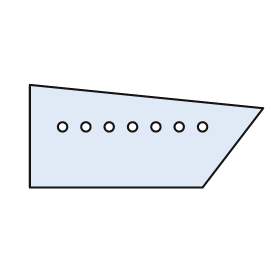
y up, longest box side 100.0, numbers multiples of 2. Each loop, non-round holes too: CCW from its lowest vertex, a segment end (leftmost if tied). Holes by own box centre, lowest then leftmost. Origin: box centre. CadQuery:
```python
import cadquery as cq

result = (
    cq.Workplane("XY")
    .moveTo(-50.0, -22.0)
    .lineTo(24.0, -22.0)
    .lineTo(50.0, 12.0)
    .lineTo(-50.0, 22.0)
    .close()
    .moveTo(-36.0, 4.0)
    .circle(2.0)
    .moveTo(-26.0, 4.0)
    .circle(2.0)
    .moveTo(-16.0, 4.0)
    .circle(2.0)
    .moveTo(-6.0, 4.0)
    .circle(2.0)
    .moveTo(4.0, 4.0)
    .circle(2.0)
    .moveTo(14.0, 4.0)
    .circle(2.0)
    .moveTo(24.0, 4.0)
    .circle(2.0)
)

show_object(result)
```